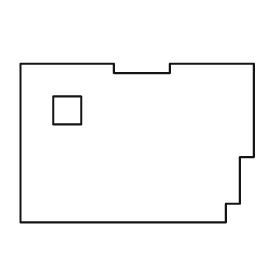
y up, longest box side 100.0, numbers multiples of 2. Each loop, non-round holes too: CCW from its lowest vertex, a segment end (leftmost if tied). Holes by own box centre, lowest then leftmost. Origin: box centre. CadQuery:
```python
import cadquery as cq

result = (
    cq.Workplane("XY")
    .moveTo(-50.0, -34.0)
    .lineTo(38.0, -34.0)
    .lineTo(38.0, -26.0)
    .lineTo(44.0, -26.0)
    .lineTo(44.0, -6.0)
    .lineTo(50.0, -6.0)
    .lineTo(50.0, 34.0)
    .lineTo(14.0, 34.0)
    .lineTo(14.0, 30.0)
    .lineTo(-10.0, 30.0)
    .lineTo(-10.0, 34.0)
    .lineTo(-50.0, 34.0)
    .close()
    .moveTo(-36.0, 8.0)
    .lineTo(-24.0, 8.0)
    .lineTo(-24.0, 20.0)
    .lineTo(-36.0, 20.0)
    .close()
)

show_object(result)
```